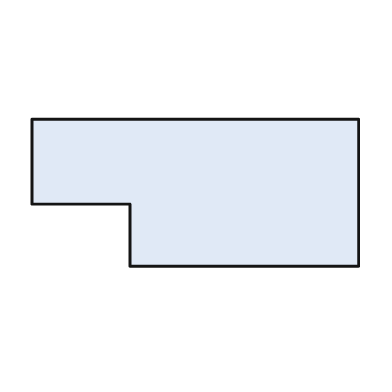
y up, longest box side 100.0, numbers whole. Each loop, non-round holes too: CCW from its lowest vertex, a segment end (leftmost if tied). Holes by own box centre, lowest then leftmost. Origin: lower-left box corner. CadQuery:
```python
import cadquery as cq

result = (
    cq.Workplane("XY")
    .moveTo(30.0, 0.0)
    .lineTo(100.0, 0.0)
    .lineTo(100.0, 45.0)
    .lineTo(0.0, 45.0)
    .lineTo(0.0, 19.0)
    .lineTo(30.0, 19.0)
    .close()
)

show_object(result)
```